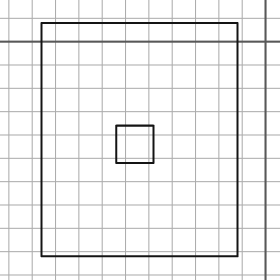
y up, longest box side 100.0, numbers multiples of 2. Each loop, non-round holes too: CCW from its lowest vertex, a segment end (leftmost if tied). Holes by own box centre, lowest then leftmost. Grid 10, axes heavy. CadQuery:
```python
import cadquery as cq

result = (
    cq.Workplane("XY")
    .moveTo(-96.0, -92.0)
    .lineTo(-12.0, -92.0)
    .lineTo(-12.0, 8.0)
    .lineTo(-96.0, 8.0)
    .close()
    .moveTo(-64.0, -52.0)
    .lineTo(-48.0, -52.0)
    .lineTo(-48.0, -36.0)
    .lineTo(-64.0, -36.0)
    .close()
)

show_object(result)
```